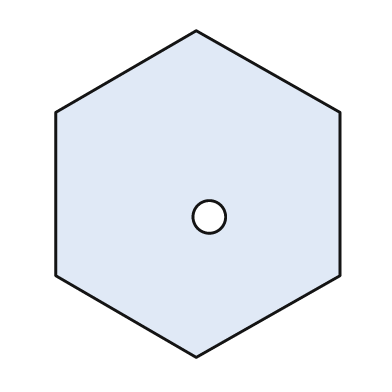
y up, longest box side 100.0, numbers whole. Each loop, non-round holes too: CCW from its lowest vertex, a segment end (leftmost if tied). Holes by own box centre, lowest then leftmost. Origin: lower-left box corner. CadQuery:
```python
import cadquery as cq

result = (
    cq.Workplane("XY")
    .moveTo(43.0, 0.0)
    .lineTo(87.0, 25.0)
    .lineTo(87.0, 75.0)
    .lineTo(43.0, 100.0)
    .lineTo(0.0, 75.0)
    .lineTo(0.0, 25.0)
    .close()
    .moveTo(47.0, 43.0)
    .circle(5.0)
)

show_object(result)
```